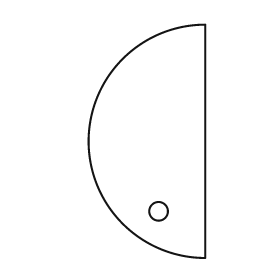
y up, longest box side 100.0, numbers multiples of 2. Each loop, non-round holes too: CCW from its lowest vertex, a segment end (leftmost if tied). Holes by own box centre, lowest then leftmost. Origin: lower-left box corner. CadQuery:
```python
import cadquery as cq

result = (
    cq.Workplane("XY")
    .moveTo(50.0, 0.0)
    .lineTo(50.0, 100.0)
    .threePointArc((0.0, 50.0), (50.0, 0.0))
    .close()
    .moveTo(30.0, 20.0)
    .circle(4.0)
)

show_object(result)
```